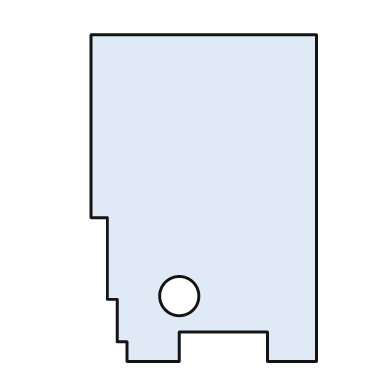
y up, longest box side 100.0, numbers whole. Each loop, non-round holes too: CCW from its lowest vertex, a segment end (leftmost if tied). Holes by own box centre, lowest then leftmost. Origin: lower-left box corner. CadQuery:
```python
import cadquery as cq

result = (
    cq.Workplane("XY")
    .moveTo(11.0, 0.0)
    .lineTo(27.0, 0.0)
    .lineTo(27.0, 9.0)
    .lineTo(54.0, 9.0)
    .lineTo(54.0, 0.0)
    .lineTo(69.0, 0.0)
    .lineTo(69.0, 100.0)
    .lineTo(0.0, 100.0)
    .lineTo(0.0, 44.0)
    .lineTo(5.0, 44.0)
    .lineTo(5.0, 19.0)
    .lineTo(8.0, 19.0)
    .lineTo(8.0, 6.0)
    .lineTo(11.0, 6.0)
    .close()
    .moveTo(27.0, 20.0)
    .circle(6.0)
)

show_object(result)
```